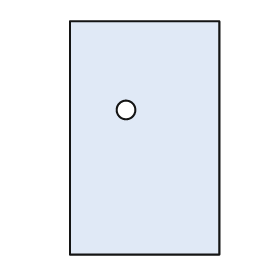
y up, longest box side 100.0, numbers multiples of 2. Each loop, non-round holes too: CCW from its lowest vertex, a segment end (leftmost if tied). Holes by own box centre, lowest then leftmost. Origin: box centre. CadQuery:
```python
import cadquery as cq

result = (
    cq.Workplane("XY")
    .moveTo(-32.0, -50.0)
    .lineTo(32.0, -50.0)
    .lineTo(32.0, 50.0)
    .lineTo(-32.0, 50.0)
    .close()
    .moveTo(-8.0, 12.0)
    .circle(4.0)
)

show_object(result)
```